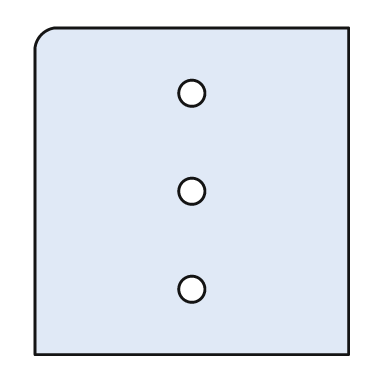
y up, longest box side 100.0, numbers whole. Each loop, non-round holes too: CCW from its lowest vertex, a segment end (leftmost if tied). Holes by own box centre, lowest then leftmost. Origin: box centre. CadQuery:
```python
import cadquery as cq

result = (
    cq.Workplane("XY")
    .moveTo(-48.0, -50.0)
    .lineTo(48.0, -50.0)
    .lineTo(48.0, 50.0)
    .lineTo(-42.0, 50.0)
    .threePointArc((-46.0, 48.0), (-48.0, 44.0))
    .close()
    .moveTo(0.0, -30.0)
    .circle(4.0)
    .moveTo(0.0, 0.0)
    .circle(4.0)
    .moveTo(0.0, 30.0)
    .circle(4.0)
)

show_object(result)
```